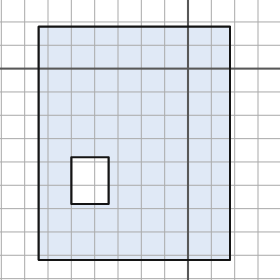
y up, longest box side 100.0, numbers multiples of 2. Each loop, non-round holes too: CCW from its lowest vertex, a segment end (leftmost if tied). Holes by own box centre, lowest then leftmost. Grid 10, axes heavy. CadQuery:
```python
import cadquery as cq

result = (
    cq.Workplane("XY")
    .moveTo(-64.0, -82.0)
    .lineTo(18.0, -82.0)
    .lineTo(18.0, 18.0)
    .lineTo(-64.0, 18.0)
    .close()
    .moveTo(-50.0, -58.0)
    .lineTo(-34.0, -58.0)
    .lineTo(-34.0, -38.0)
    .lineTo(-50.0, -38.0)
    .close()
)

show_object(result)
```